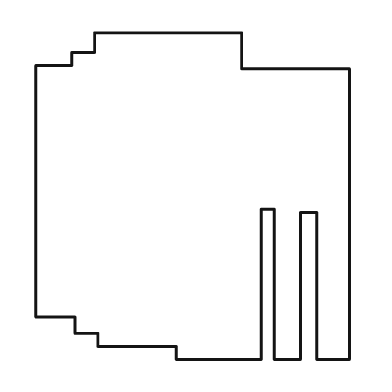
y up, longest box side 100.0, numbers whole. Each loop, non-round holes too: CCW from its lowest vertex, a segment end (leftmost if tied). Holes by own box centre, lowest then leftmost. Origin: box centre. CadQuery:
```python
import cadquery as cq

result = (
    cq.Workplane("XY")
    .moveTo(-5.0, -50.0)
    .lineTo(21.0, -50.0)
    .lineTo(21.0, -4.0)
    .lineTo(25.0, -4.0)
    .lineTo(25.0, -50.0)
    .lineTo(33.0, -50.0)
    .lineTo(33.0, -5.0)
    .lineTo(38.0, -5.0)
    .lineTo(38.0, -50.0)
    .lineTo(48.0, -50.0)
    .lineTo(48.0, 39.0)
    .lineTo(15.0, 39.0)
    .lineTo(15.0, 50.0)
    .lineTo(-30.0, 50.0)
    .lineTo(-30.0, 44.0)
    .lineTo(-37.0, 44.0)
    .lineTo(-37.0, 40.0)
    .lineTo(-48.0, 40.0)
    .lineTo(-48.0, -37.0)
    .lineTo(-36.0, -37.0)
    .lineTo(-36.0, -42.0)
    .lineTo(-29.0, -42.0)
    .lineTo(-29.0, -46.0)
    .lineTo(-5.0, -46.0)
    .close()
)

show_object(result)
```